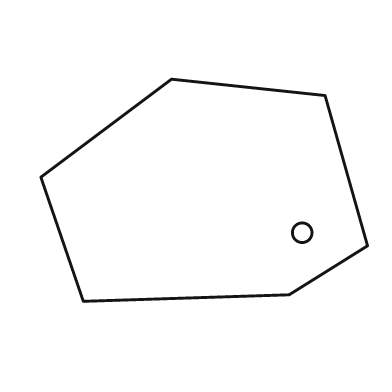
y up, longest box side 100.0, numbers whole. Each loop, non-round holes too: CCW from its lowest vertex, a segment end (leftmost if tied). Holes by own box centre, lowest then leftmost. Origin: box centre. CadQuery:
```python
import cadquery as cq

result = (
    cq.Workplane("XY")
    .moveTo(-37.0, -34.0)
    .lineTo(26.0, -32.0)
    .lineTo(50.0, -17.0)
    .lineTo(37.0, 29.0)
    .lineTo(-10.0, 34.0)
    .lineTo(-50.0, 4.0)
    .close()
    .moveTo(30.0, -13.0)
    .circle(3.0)
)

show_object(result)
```